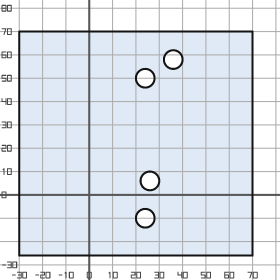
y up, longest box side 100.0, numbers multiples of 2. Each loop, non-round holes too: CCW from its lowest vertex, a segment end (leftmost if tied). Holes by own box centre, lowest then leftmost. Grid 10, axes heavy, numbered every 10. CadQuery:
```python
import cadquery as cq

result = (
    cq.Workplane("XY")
    .moveTo(-30.0, -26.0)
    .lineTo(70.0, -26.0)
    .lineTo(70.0, 70.0)
    .lineTo(-30.0, 70.0)
    .close()
    .moveTo(24.0, -10.0)
    .circle(4.0)
    .moveTo(26.0, 6.0)
    .circle(4.0)
    .moveTo(24.0, 50.0)
    .circle(4.0)
    .moveTo(36.0, 58.0)
    .circle(4.0)
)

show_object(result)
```